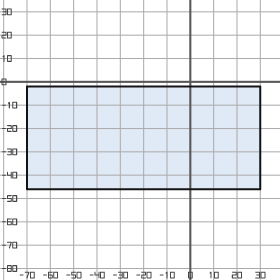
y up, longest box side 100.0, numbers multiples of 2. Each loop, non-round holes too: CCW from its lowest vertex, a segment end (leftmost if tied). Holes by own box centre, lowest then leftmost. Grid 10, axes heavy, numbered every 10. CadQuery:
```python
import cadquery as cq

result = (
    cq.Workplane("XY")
    .moveTo(-70.0, -46.0)
    .lineTo(30.0, -46.0)
    .lineTo(30.0, -2.0)
    .lineTo(-70.0, -2.0)
    .close()
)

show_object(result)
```